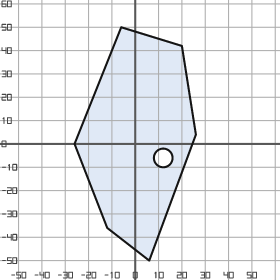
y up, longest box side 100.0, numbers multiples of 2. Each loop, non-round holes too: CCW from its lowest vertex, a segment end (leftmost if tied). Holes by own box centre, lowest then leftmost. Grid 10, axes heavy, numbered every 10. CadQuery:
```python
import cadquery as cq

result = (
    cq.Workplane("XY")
    .moveTo(6.0, -50.0)
    .lineTo(26.0, 4.0)
    .lineTo(20.0, 42.0)
    .lineTo(-6.0, 50.0)
    .lineTo(-26.0, 0.0)
    .lineTo(-12.0, -36.0)
    .close()
    .moveTo(12.0, -6.0)
    .circle(4.0)
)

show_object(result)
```